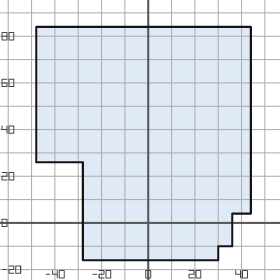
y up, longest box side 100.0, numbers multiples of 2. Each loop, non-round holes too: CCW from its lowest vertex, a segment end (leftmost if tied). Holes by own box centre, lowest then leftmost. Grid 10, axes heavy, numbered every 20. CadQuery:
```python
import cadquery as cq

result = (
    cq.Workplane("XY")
    .moveTo(-28.0, -16.0)
    .lineTo(30.0, -16.0)
    .lineTo(30.0, -10.0)
    .lineTo(36.0, -10.0)
    .lineTo(36.0, 4.0)
    .lineTo(44.0, 4.0)
    .lineTo(44.0, 84.0)
    .lineTo(-48.0, 84.0)
    .lineTo(-48.0, 26.0)
    .lineTo(-28.0, 26.0)
    .close()
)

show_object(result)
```